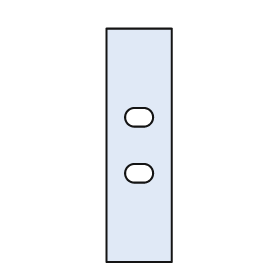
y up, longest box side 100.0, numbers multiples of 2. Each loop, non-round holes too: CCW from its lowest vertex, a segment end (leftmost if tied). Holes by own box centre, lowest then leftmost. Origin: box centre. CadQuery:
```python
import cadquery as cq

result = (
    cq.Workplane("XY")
    .moveTo(-14.0, -50.0)
    .lineTo(14.0, -50.0)
    .lineTo(14.0, 50.0)
    .lineTo(-14.0, 50.0)
    .close()
    .moveTo(-2.0, -16.0)
    .lineTo(2.0, -16.0)
    .threePointArc((6.0, -12.0), (2.0, -8.0))
    .lineTo(-2.0, -8.0)
    .threePointArc((-6.0, -12.0), (-2.0, -16.0))
    .close()
    .moveTo(-2.0, 8.0)
    .lineTo(2.0, 8.0)
    .threePointArc((6.0, 12.0), (2.0, 16.0))
    .lineTo(-2.0, 16.0)
    .threePointArc((-6.0, 12.0), (-2.0, 8.0))
    .close()
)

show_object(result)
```